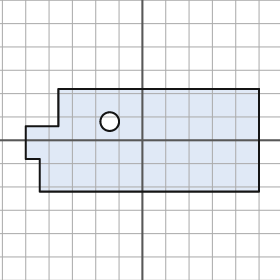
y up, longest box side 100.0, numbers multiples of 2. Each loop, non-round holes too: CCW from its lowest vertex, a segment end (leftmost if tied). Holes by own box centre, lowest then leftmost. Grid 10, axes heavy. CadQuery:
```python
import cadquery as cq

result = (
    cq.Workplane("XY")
    .moveTo(-44.0, -22.0)
    .lineTo(50.0, -22.0)
    .lineTo(50.0, 22.0)
    .lineTo(-36.0, 22.0)
    .lineTo(-36.0, 6.0)
    .lineTo(-50.0, 6.0)
    .lineTo(-50.0, -8.0)
    .lineTo(-44.0, -8.0)
    .close()
    .moveTo(-14.0, 8.0)
    .circle(4.0)
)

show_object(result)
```